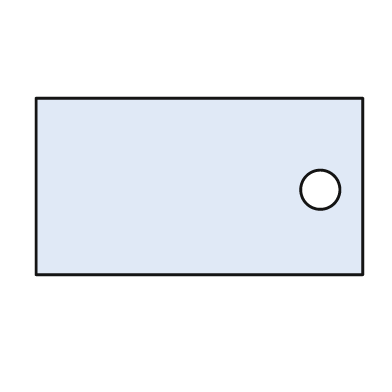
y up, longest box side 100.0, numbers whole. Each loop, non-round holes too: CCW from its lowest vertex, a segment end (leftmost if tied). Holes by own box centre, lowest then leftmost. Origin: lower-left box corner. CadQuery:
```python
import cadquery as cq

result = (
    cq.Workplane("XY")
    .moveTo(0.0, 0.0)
    .lineTo(100.0, 0.0)
    .lineTo(100.0, 54.0)
    .lineTo(0.0, 54.0)
    .close()
    .moveTo(87.0, 26.0)
    .circle(6.0)
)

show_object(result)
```